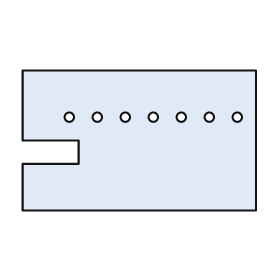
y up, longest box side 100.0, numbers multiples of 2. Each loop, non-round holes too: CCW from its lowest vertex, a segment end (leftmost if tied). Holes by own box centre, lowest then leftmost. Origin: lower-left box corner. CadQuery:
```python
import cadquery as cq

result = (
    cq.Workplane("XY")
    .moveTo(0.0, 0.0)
    .lineTo(100.0, 0.0)
    .lineTo(100.0, 60.0)
    .lineTo(0.0, 60.0)
    .lineTo(0.0, 30.0)
    .lineTo(24.0, 30.0)
    .lineTo(24.0, 20.0)
    .lineTo(0.0, 20.0)
    .close()
    .moveTo(20.0, 40.0)
    .circle(2.0)
    .moveTo(32.0, 40.0)
    .circle(2.0)
    .moveTo(44.0, 40.0)
    .circle(2.0)
    .moveTo(56.0, 40.0)
    .circle(2.0)
    .moveTo(68.0, 40.0)
    .circle(2.0)
    .moveTo(80.0, 40.0)
    .circle(2.0)
    .moveTo(92.0, 40.0)
    .circle(2.0)
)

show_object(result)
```